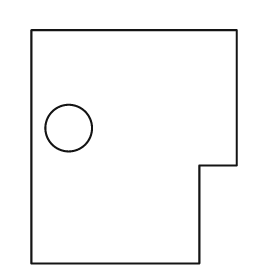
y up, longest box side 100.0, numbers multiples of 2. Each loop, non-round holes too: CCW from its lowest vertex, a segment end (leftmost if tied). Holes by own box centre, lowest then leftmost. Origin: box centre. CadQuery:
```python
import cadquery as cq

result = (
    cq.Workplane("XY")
    .moveTo(-44.0, -50.0)
    .lineTo(28.0, -50.0)
    .lineTo(28.0, -8.0)
    .lineTo(44.0, -8.0)
    .lineTo(44.0, 50.0)
    .lineTo(-44.0, 50.0)
    .close()
    .moveTo(-28.0, 8.0)
    .circle(10.0)
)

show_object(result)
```